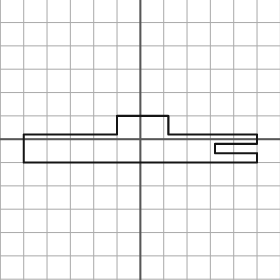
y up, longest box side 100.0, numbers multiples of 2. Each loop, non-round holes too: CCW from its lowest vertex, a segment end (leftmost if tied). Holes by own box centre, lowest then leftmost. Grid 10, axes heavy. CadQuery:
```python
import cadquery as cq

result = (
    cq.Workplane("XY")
    .moveTo(-50.0, -10.0)
    .lineTo(50.0, -10.0)
    .lineTo(50.0, -6.0)
    .lineTo(32.0, -6.0)
    .lineTo(32.0, -2.0)
    .lineTo(50.0, -2.0)
    .lineTo(50.0, 2.0)
    .lineTo(12.0, 2.0)
    .lineTo(12.0, 10.0)
    .lineTo(-10.0, 10.0)
    .lineTo(-10.0, 2.0)
    .lineTo(-50.0, 2.0)
    .close()
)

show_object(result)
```